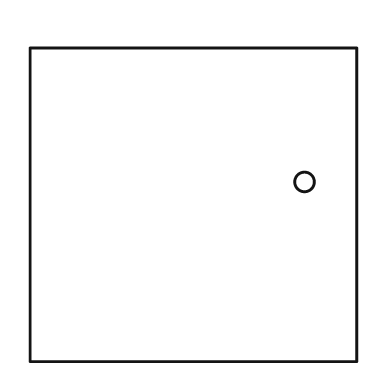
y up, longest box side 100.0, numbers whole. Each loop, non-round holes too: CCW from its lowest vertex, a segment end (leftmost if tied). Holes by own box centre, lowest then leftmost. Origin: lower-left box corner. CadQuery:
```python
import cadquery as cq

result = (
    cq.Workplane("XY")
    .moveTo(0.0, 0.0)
    .lineTo(100.0, 0.0)
    .lineTo(100.0, 96.0)
    .lineTo(0.0, 96.0)
    .close()
    .moveTo(84.0, 55.0)
    .circle(3.0)
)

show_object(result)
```